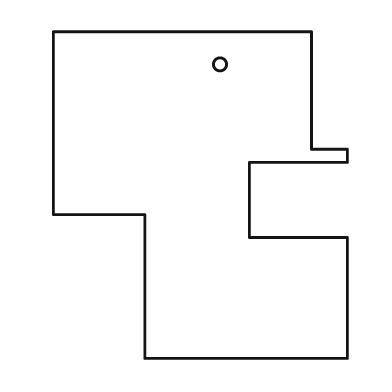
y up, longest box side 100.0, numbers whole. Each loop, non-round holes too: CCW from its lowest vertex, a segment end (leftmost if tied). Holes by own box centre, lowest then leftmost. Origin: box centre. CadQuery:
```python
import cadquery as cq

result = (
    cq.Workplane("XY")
    .moveTo(-17.0, -50.0)
    .lineTo(45.0, -50.0)
    .lineTo(45.0, -13.0)
    .lineTo(15.0, -13.0)
    .lineTo(15.0, 10.0)
    .lineTo(45.0, 10.0)
    .lineTo(45.0, 14.0)
    .lineTo(34.0, 14.0)
    .lineTo(34.0, 50.0)
    .lineTo(-45.0, 50.0)
    .lineTo(-45.0, -6.0)
    .lineTo(-17.0, -6.0)
    .close()
    .moveTo(6.0, 40.0)
    .circle(2.0)
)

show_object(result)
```